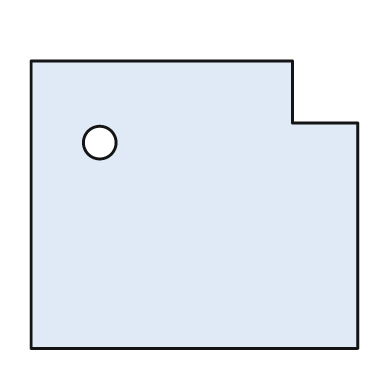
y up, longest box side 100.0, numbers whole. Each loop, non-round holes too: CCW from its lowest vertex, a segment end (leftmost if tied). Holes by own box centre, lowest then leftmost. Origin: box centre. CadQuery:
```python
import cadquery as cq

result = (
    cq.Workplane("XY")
    .moveTo(-50.0, -44.0)
    .lineTo(50.0, -44.0)
    .lineTo(50.0, 25.0)
    .lineTo(30.0, 25.0)
    .lineTo(30.0, 44.0)
    .lineTo(-50.0, 44.0)
    .close()
    .moveTo(-29.0, 19.0)
    .circle(5.0)
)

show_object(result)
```